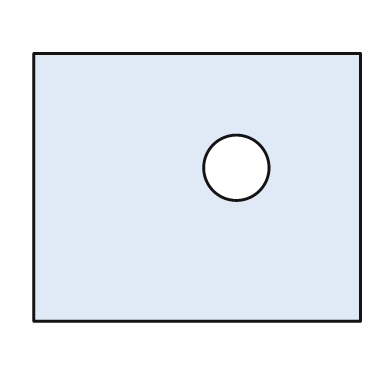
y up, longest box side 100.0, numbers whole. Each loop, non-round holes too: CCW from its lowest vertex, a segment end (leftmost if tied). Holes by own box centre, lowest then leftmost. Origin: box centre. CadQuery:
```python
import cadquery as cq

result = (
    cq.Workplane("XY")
    .moveTo(-50.0, -41.0)
    .lineTo(50.0, -41.0)
    .lineTo(50.0, 41.0)
    .lineTo(-50.0, 41.0)
    .close()
    .moveTo(12.0, 6.0)
    .circle(10.0)
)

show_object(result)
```